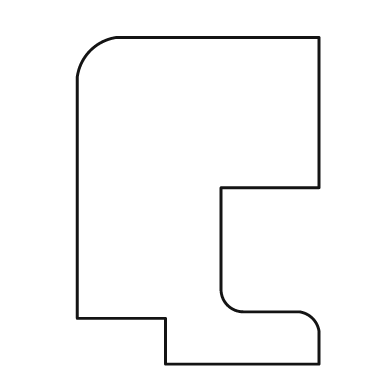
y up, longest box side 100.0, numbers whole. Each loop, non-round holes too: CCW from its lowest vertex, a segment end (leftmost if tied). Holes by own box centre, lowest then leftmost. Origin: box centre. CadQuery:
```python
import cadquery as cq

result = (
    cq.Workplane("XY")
    .moveTo(-10.0, -50.0)
    .lineTo(37.0, -50.0)
    .lineTo(37.0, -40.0)
    .threePointArc((35.0, -36.0), (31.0, -34.0))
    .lineTo(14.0, -34.0)
    .threePointArc((9.0, -32.0), (7.0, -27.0))
    .lineTo(7.0, 4.0)
    .lineTo(37.0, 4.0)
    .lineTo(37.0, 50.0)
    .lineTo(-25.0, 50.0)
    .threePointArc((-33.0, 46.0), (-37.0, 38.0))
    .lineTo(-37.0, -36.0)
    .lineTo(-10.0, -36.0)
    .close()
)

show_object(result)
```